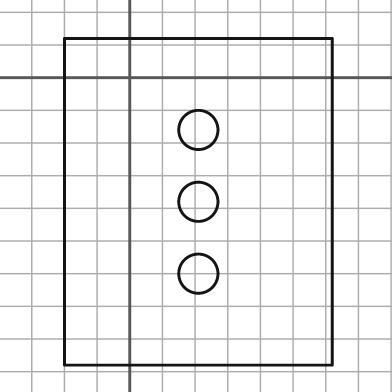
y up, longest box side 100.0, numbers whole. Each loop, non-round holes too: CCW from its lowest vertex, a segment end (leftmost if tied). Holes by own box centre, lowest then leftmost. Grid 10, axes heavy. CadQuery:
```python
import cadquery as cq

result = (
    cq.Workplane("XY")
    .moveTo(-20.0, -88.0)
    .lineTo(62.0, -88.0)
    .lineTo(62.0, 12.0)
    .lineTo(-20.0, 12.0)
    .close()
    .moveTo(21.0, -60.0)
    .circle(6.0)
    .moveTo(21.0, -38.0)
    .circle(6.0)
    .moveTo(21.0, -16.0)
    .circle(6.0)
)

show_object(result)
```